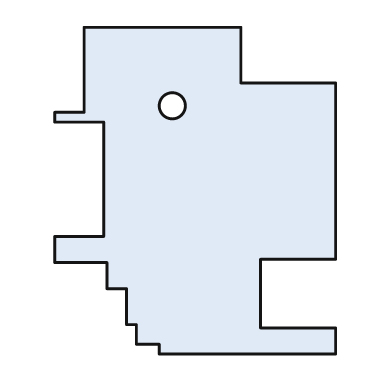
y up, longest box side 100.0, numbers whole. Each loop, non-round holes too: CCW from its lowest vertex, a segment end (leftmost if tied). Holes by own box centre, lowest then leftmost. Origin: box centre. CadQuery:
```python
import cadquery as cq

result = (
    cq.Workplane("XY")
    .moveTo(-11.0, -50.0)
    .lineTo(43.0, -50.0)
    .lineTo(43.0, -42.0)
    .lineTo(20.0, -42.0)
    .lineTo(20.0, -21.0)
    .lineTo(43.0, -21.0)
    .lineTo(43.0, 33.0)
    .lineTo(14.0, 33.0)
    .lineTo(14.0, 50.0)
    .lineTo(-34.0, 50.0)
    .lineTo(-34.0, 24.0)
    .lineTo(-43.0, 24.0)
    .lineTo(-43.0, 21.0)
    .lineTo(-28.0, 21.0)
    .lineTo(-28.0, -14.0)
    .lineTo(-43.0, -14.0)
    .lineTo(-43.0, -22.0)
    .lineTo(-27.0, -22.0)
    .lineTo(-27.0, -30.0)
    .lineTo(-21.0, -30.0)
    .lineTo(-21.0, -41.0)
    .lineTo(-18.0, -41.0)
    .lineTo(-18.0, -47.0)
    .lineTo(-11.0, -47.0)
    .close()
    .moveTo(-7.0, 26.0)
    .circle(4.0)
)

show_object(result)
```